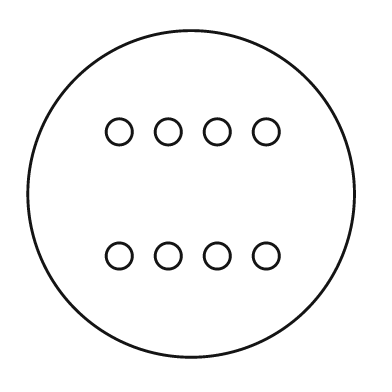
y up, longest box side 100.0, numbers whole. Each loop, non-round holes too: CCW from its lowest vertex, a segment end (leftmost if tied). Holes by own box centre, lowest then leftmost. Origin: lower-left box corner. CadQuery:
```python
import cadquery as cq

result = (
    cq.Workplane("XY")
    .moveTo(50.0, 50.0)
    .circle(50.0)
    .moveTo(28.0, 31.0)
    .circle(4.0)
    .moveTo(43.0, 31.0)
    .circle(4.0)
    .moveTo(58.0, 31.0)
    .circle(4.0)
    .moveTo(73.0, 31.0)
    .circle(4.0)
    .moveTo(28.0, 69.0)
    .circle(4.0)
    .moveTo(43.0, 69.0)
    .circle(4.0)
    .moveTo(58.0, 69.0)
    .circle(4.0)
    .moveTo(73.0, 69.0)
    .circle(4.0)
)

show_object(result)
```